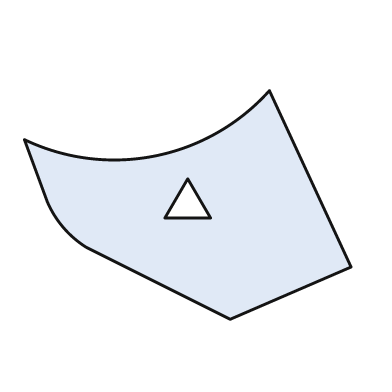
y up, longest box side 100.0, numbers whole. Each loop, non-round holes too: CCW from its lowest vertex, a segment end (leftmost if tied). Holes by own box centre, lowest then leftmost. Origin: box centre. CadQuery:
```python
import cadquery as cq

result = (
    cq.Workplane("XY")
    .moveTo(13.0, -35.0)
    .lineTo(50.0, -19.0)
    .lineTo(25.0, 35.0)
    .threePointArc((-10.0, 15.0), (-50.0, 20.0))
    .lineTo(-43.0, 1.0)
    .threePointArc((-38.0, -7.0), (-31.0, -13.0))
    .close()
    .moveTo(-7.0, -4.0)
    .lineTo(7.0, -4.0)
    .lineTo(0.0, 8.0)
    .close()
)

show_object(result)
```